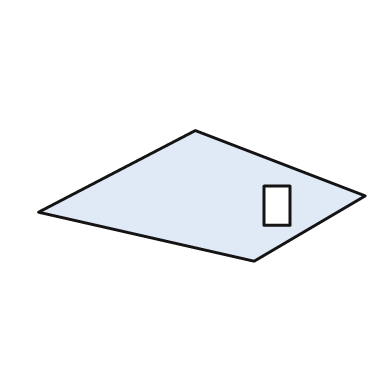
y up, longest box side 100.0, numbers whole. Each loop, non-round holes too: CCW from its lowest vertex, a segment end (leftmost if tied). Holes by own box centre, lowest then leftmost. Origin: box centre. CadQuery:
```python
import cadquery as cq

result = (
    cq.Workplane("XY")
    .moveTo(16.0, -20.0)
    .lineTo(50.0, 0.0)
    .lineTo(-2.0, 20.0)
    .lineTo(-50.0, -5.0)
    .close()
    .moveTo(19.0, -9.0)
    .lineTo(27.0, -9.0)
    .lineTo(27.0, 3.0)
    .lineTo(19.0, 3.0)
    .close()
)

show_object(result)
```